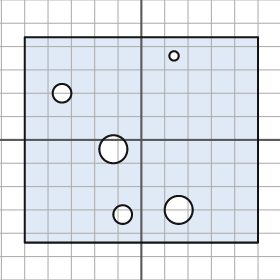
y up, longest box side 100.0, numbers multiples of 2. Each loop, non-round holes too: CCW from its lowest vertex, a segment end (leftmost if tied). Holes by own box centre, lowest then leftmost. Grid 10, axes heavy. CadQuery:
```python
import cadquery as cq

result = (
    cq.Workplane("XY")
    .moveTo(-50.0, -44.0)
    .lineTo(50.0, -44.0)
    .lineTo(50.0, 44.0)
    .lineTo(-50.0, 44.0)
    .close()
    .moveTo(-8.0, -32.0)
    .circle(4.0)
    .moveTo(16.0, -30.0)
    .circle(6.0)
    .moveTo(-12.0, -4.0)
    .circle(6.0)
    .moveTo(-34.0, 20.0)
    .circle(4.0)
    .moveTo(14.0, 36.0)
    .circle(2.0)
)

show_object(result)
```